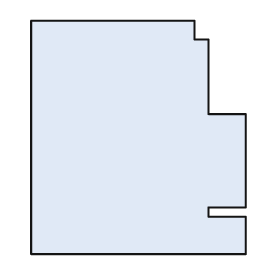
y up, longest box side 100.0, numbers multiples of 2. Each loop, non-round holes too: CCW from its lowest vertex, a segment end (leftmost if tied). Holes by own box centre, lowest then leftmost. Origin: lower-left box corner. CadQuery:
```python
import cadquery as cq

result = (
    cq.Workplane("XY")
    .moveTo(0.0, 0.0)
    .lineTo(92.0, 0.0)
    .lineTo(92.0, 16.0)
    .lineTo(76.0, 16.0)
    .lineTo(76.0, 20.0)
    .lineTo(92.0, 20.0)
    .lineTo(92.0, 60.0)
    .lineTo(76.0, 60.0)
    .lineTo(76.0, 92.0)
    .lineTo(70.0, 92.0)
    .lineTo(70.0, 100.0)
    .lineTo(0.0, 100.0)
    .close()
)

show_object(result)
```